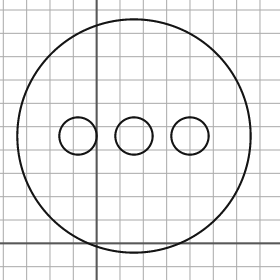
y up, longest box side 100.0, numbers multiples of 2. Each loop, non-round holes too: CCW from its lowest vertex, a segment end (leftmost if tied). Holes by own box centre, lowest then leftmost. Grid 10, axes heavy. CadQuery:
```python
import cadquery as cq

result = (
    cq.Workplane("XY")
    .moveTo(16.0, 46.0)
    .circle(50.0)
    .moveTo(-8.0, 46.0)
    .circle(8.0)
    .moveTo(16.0, 46.0)
    .circle(8.0)
    .moveTo(40.0, 46.0)
    .circle(8.0)
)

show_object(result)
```